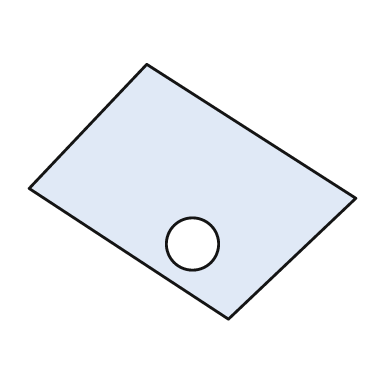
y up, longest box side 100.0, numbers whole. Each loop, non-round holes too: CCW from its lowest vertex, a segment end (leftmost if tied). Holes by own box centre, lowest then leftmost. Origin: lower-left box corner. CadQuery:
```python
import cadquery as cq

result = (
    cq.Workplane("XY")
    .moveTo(61.0, 0.0)
    .lineTo(100.0, 37.0)
    .lineTo(36.0, 78.0)
    .lineTo(0.0, 40.0)
    .close()
    .moveTo(50.0, 23.0)
    .circle(8.0)
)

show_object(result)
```